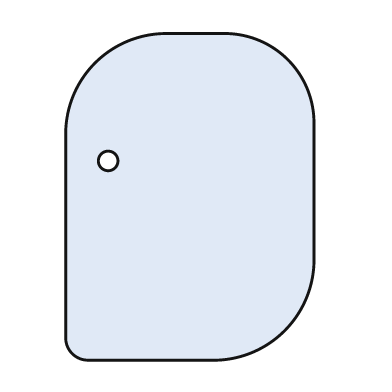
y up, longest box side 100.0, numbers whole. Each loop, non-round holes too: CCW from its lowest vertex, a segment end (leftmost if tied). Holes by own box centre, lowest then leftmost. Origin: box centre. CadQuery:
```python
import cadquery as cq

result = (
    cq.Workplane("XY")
    .moveTo(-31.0, -50.0)
    .lineTo(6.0, -50.0)
    .threePointArc((29.0, -41.0), (38.0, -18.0))
    .lineTo(38.0, 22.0)
    .threePointArc((30.0, 42.0), (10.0, 50.0))
    .lineTo(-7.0, 50.0)
    .threePointArc((-29.0, 41.0), (-38.0, 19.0))
    .lineTo(-38.0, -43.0)
    .threePointArc((-36.0, -48.0), (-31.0, -50.0))
    .close()
    .moveTo(-25.0, 11.0)
    .circle(3.0)
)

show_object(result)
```